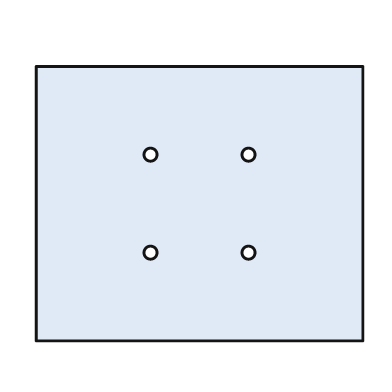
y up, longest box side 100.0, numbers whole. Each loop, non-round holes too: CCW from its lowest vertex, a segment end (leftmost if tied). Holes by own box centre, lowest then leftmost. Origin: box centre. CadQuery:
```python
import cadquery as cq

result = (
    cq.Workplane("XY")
    .moveTo(-50.0, -42.0)
    .lineTo(50.0, -42.0)
    .lineTo(50.0, 42.0)
    .lineTo(-50.0, 42.0)
    .close()
    .moveTo(-15.0, -15.0)
    .circle(2.0)
    .moveTo(15.0, -15.0)
    .circle(2.0)
    .moveTo(-15.0, 15.0)
    .circle(2.0)
    .moveTo(15.0, 15.0)
    .circle(2.0)
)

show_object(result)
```